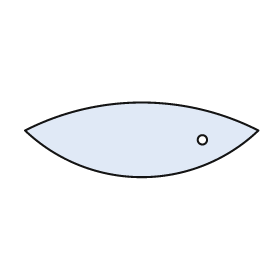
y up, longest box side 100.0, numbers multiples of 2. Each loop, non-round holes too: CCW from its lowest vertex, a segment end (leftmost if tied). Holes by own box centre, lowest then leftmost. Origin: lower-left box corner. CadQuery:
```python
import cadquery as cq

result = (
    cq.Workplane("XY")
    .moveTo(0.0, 20.0)
    .threePointArc((50.0, 0.0), (100.0, 20.0))
    .threePointArc((50.0, 32.0), (0.0, 20.0))
    .close()
    .moveTo(76.0, 16.0)
    .circle(2.0)
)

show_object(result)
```